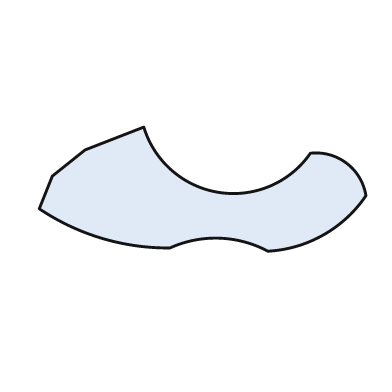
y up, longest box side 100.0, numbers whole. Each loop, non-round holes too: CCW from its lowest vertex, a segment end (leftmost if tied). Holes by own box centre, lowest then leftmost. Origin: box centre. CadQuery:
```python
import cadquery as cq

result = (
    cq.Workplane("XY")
    .moveTo(20.0, -19.0)
    .threePointArc((37.0, -14.0), (50.0, -2.0))
    .threePointArc((44.0, 8.0), (33.0, 11.0))
    .threePointArc((5.0, -1.0), (-18.0, 19.0))
    .lineTo(-36.0, 12.0)
    .lineTo(-46.0, 4.0)
    .lineTo(-50.0, -6.0)
    .threePointArc((-31.0, -15.0), (-10.0, -18.0))
    .threePointArc((5.0, -15.0), (20.0, -19.0))
    .close()
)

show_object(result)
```